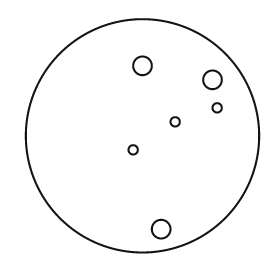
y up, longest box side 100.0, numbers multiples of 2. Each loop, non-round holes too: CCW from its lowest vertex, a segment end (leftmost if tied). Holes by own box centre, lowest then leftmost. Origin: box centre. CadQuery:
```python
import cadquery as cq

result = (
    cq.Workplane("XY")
    .moveTo(0.0, 0.0)
    .circle(50.0)
    .moveTo(8.0, -40.0)
    .circle(4.0)
    .moveTo(-4.0, -6.0)
    .circle(2.0)
    .moveTo(14.0, 6.0)
    .circle(2.0)
    .moveTo(32.0, 12.0)
    .circle(2.0)
    .moveTo(30.0, 24.0)
    .circle(4.0)
    .moveTo(0.0, 30.0)
    .circle(4.0)
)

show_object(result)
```